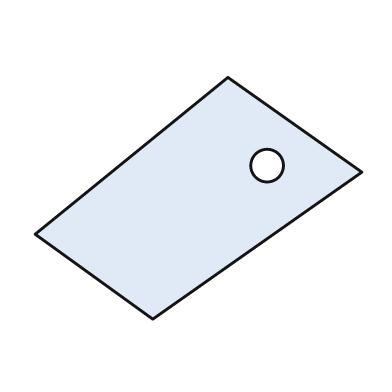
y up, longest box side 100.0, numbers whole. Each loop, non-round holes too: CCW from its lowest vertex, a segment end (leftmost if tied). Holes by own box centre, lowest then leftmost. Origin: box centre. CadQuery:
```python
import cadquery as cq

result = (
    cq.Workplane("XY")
    .moveTo(-14.0, -37.0)
    .lineTo(50.0, 8.0)
    .lineTo(9.0, 37.0)
    .lineTo(-50.0, -11.0)
    .close()
    .moveTo(21.0, 10.0)
    .circle(5.0)
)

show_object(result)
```